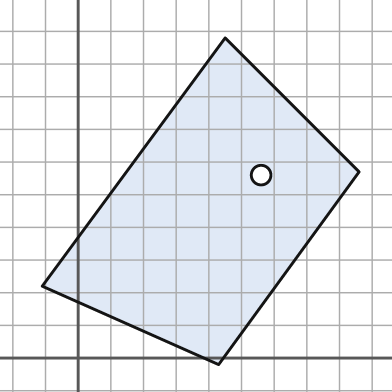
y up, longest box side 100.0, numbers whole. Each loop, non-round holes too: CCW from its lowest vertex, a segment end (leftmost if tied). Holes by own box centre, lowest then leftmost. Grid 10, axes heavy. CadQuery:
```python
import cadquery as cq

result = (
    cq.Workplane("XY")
    .moveTo(43.0, -2.0)
    .lineTo(86.0, 57.0)
    .lineTo(45.0, 98.0)
    .lineTo(-11.0, 22.0)
    .close()
    .moveTo(56.0, 56.0)
    .circle(3.0)
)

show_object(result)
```